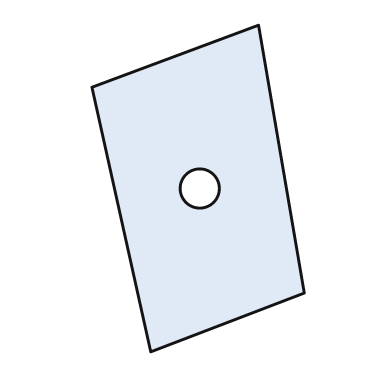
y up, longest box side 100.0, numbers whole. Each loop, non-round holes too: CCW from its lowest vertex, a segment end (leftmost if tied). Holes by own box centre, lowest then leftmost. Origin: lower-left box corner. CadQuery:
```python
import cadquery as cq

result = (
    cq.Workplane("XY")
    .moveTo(18.0, 0.0)
    .lineTo(65.0, 18.0)
    .lineTo(51.0, 100.0)
    .lineTo(0.0, 81.0)
    .close()
    .moveTo(33.0, 50.0)
    .circle(6.0)
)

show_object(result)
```